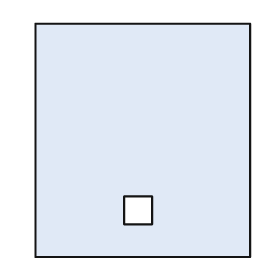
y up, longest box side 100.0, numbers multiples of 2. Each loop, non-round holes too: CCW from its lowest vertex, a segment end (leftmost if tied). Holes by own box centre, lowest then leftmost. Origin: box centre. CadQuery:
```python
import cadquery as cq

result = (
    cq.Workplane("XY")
    .moveTo(-46.0, -50.0)
    .lineTo(46.0, -50.0)
    .lineTo(46.0, 50.0)
    .lineTo(-46.0, 50.0)
    .close()
    .moveTo(-8.0, -36.0)
    .lineTo(4.0, -36.0)
    .lineTo(4.0, -24.0)
    .lineTo(-8.0, -24.0)
    .close()
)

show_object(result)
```